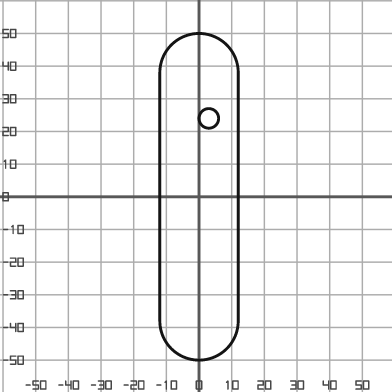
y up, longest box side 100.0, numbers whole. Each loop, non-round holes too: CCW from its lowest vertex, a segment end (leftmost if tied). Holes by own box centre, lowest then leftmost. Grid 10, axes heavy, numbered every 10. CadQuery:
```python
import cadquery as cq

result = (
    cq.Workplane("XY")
    .moveTo(-12.0, -38.0)
    .threePointArc((0.0, -50.0), (12.0, -38.0))
    .lineTo(12.0, 38.0)
    .threePointArc((0.0, 50.0), (-12.0, 38.0))
    .close()
    .moveTo(3.0, 24.0)
    .circle(3.0)
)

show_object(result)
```